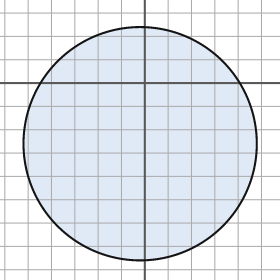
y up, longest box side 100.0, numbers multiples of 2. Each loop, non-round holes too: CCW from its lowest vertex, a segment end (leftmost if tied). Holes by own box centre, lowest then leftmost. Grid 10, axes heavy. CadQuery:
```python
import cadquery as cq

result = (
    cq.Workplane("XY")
    .moveTo(-2.0, -26.0)
    .circle(50.0)
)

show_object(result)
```